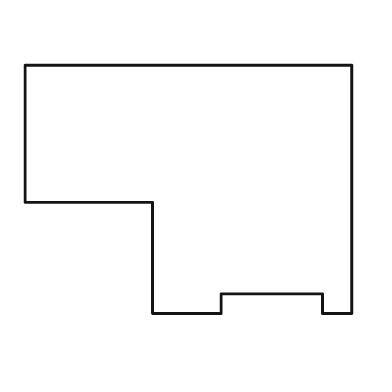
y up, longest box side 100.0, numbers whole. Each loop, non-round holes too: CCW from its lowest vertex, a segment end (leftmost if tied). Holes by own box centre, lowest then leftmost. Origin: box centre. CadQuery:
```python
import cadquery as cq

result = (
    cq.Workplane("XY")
    .moveTo(-11.0, -38.0)
    .lineTo(10.0, -38.0)
    .lineTo(10.0, -32.0)
    .lineTo(41.0, -32.0)
    .lineTo(41.0, -38.0)
    .lineTo(50.0, -38.0)
    .lineTo(50.0, 38.0)
    .lineTo(-50.0, 38.0)
    .lineTo(-50.0, -4.0)
    .lineTo(-11.0, -4.0)
    .close()
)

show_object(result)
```